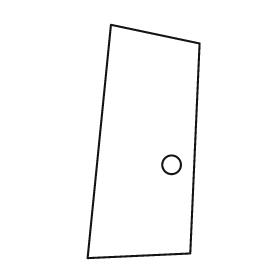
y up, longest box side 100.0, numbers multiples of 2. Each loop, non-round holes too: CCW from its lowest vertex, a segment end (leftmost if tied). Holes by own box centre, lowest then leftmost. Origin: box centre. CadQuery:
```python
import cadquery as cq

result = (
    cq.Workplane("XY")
    .moveTo(-24.0, -50.0)
    .lineTo(20.0, -48.0)
    .lineTo(24.0, 42.0)
    .lineTo(-14.0, 50.0)
    .close()
    .moveTo(12.0, -10.0)
    .circle(4.0)
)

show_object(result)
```